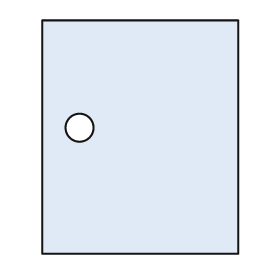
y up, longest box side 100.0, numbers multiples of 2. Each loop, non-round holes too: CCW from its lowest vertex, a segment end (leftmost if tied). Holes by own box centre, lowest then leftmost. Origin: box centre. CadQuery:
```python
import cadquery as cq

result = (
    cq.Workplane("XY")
    .moveTo(-42.0, -50.0)
    .lineTo(42.0, -50.0)
    .lineTo(42.0, 50.0)
    .lineTo(-42.0, 50.0)
    .close()
    .moveTo(-26.0, 4.0)
    .circle(6.0)
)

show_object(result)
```